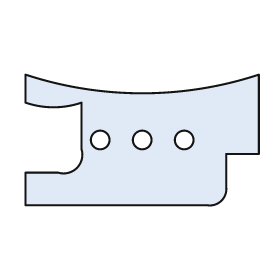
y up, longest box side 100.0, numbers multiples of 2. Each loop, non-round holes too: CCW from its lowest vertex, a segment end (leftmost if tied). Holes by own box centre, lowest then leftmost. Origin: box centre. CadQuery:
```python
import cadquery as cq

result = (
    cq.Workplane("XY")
    .moveTo(-50.0, -28.0)
    .lineTo(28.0, -28.0)
    .threePointArc((34.0, -26.0), (36.0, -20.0))
    .lineTo(36.0, -6.0)
    .lineTo(50.0, -6.0)
    .lineTo(50.0, 28.0)
    .threePointArc((0.0, 20.0), (-50.0, 28.0))
    .lineTo(-50.0, 16.0)
    .threePointArc((-38.0, 14.0), (-26.0, 16.0))
    .lineTo(-26.0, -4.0)
    .threePointArc((-28.0, -12.0), (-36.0, -14.0))
    .lineTo(-50.0, -14.0)
    .close()
    .moveTo(-18.0, 0.0)
    .circle(4.0)
    .moveTo(0.0, 0.0)
    .circle(4.0)
    .moveTo(18.0, 0.0)
    .circle(4.0)
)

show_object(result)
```